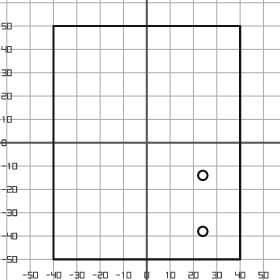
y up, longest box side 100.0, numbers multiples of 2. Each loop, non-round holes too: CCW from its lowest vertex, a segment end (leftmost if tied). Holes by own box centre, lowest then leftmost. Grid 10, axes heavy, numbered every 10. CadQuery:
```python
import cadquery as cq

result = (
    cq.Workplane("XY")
    .moveTo(-40.0, -50.0)
    .lineTo(40.0, -50.0)
    .lineTo(40.0, 50.0)
    .lineTo(-40.0, 50.0)
    .close()
    .moveTo(24.0, -38.0)
    .circle(2.0)
    .moveTo(24.0, -14.0)
    .circle(2.0)
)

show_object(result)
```